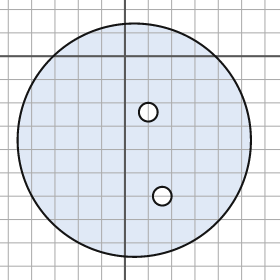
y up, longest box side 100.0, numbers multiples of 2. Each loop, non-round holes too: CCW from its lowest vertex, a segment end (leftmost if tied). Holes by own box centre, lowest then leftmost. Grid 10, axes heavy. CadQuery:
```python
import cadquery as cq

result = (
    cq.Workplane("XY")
    .moveTo(4.0, -36.0)
    .circle(50.0)
    .moveTo(16.0, -60.0)
    .circle(4.0)
    .moveTo(10.0, -24.0)
    .circle(4.0)
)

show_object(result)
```